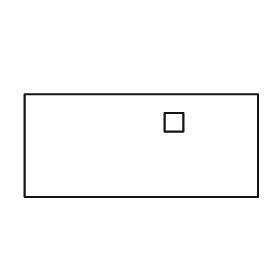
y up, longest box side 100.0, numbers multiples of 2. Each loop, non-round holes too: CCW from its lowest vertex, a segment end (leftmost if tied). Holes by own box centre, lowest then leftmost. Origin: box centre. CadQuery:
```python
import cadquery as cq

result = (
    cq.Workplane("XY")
    .moveTo(-50.0, -22.0)
    .lineTo(50.0, -22.0)
    .lineTo(50.0, 22.0)
    .lineTo(-50.0, 22.0)
    .close()
    .moveTo(10.0, 6.0)
    .lineTo(18.0, 6.0)
    .lineTo(18.0, 14.0)
    .lineTo(10.0, 14.0)
    .close()
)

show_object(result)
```